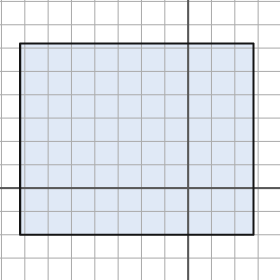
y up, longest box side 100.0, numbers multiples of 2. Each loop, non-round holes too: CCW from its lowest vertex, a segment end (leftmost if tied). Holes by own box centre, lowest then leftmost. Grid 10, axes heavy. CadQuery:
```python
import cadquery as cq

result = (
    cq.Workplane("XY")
    .moveTo(-72.0, -20.0)
    .lineTo(28.0, -20.0)
    .lineTo(28.0, 62.0)
    .lineTo(-72.0, 62.0)
    .close()
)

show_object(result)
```